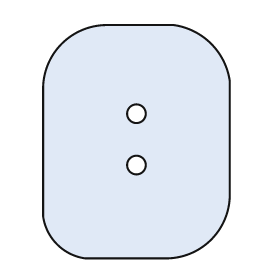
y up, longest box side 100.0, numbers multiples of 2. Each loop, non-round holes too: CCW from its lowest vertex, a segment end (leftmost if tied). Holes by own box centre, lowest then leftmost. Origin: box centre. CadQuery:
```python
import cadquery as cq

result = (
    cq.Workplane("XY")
    .moveTo(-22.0, -50.0)
    .lineTo(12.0, -50.0)
    .threePointArc((32.0, -42.0), (40.0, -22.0))
    .lineTo(40.0, 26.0)
    .threePointArc((32.0, 42.0), (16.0, 50.0))
    .lineTo(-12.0, 50.0)
    .threePointArc((-32.0, 42.0), (-40.0, 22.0))
    .lineTo(-40.0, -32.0)
    .threePointArc((-34.0, -44.0), (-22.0, -50.0))
    .close()
    .moveTo(0.0, -10.0)
    .circle(4.0)
    .moveTo(0.0, 12.0)
    .circle(4.0)
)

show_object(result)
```